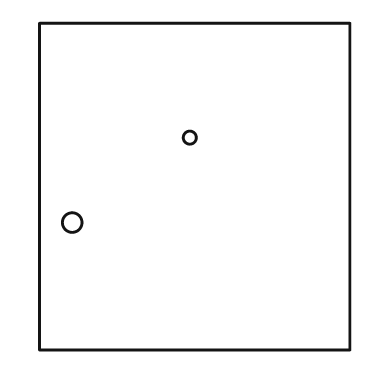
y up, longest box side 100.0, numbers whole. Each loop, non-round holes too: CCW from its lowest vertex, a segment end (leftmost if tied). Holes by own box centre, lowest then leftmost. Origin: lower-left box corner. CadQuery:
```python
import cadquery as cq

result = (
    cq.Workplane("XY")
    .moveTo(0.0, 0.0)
    .lineTo(95.0, 0.0)
    .lineTo(95.0, 100.0)
    .lineTo(0.0, 100.0)
    .close()
    .moveTo(10.0, 39.0)
    .circle(3.0)
    .moveTo(46.0, 65.0)
    .circle(2.0)
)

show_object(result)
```